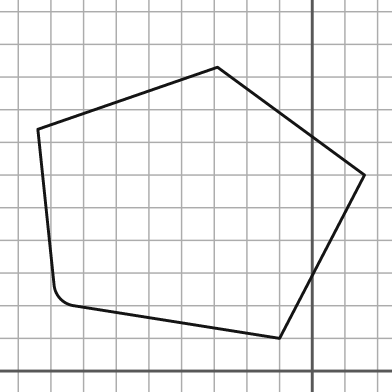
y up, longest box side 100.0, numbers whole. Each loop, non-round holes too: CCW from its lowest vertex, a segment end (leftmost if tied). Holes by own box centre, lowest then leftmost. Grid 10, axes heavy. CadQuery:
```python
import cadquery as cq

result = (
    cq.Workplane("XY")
    .moveTo(-10.0, 10.0)
    .lineTo(16.0, 60.0)
    .lineTo(-29.0, 93.0)
    .lineTo(-84.0, 74.0)
    .lineTo(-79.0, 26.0)
    .threePointArc((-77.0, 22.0), (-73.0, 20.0))
    .close()
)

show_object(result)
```